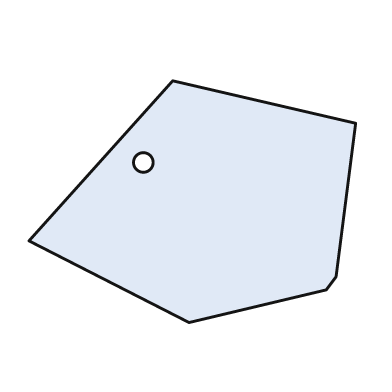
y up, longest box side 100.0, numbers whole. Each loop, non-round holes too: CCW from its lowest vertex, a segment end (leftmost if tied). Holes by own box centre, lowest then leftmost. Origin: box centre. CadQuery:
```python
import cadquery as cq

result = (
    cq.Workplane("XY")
    .moveTo(-1.0, -37.0)
    .lineTo(41.0, -27.0)
    .lineTo(44.0, -23.0)
    .lineTo(50.0, 24.0)
    .lineTo(-6.0, 37.0)
    .lineTo(-50.0, -12.0)
    .close()
    .moveTo(-15.0, 12.0)
    .circle(3.0)
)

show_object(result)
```